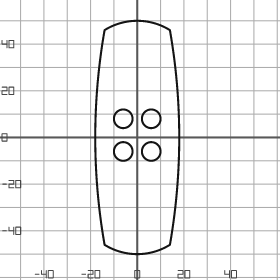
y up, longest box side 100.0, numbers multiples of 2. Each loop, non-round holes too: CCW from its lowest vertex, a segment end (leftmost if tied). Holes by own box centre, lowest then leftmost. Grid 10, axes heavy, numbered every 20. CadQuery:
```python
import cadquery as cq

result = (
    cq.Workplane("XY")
    .moveTo(-14.0, -46.0)
    .threePointArc((0.0, -50.0), (14.0, -46.0))
    .threePointArc((18.0, 0.0), (14.0, 46.0))
    .threePointArc((0.0, 50.0), (-14.0, 46.0))
    .threePointArc((-18.0, 0.0), (-14.0, -46.0))
    .close()
    .moveTo(-6.0, -6.0)
    .circle(4.0)
    .moveTo(6.0, -6.0)
    .circle(4.0)
    .moveTo(-6.0, 8.0)
    .circle(4.0)
    .moveTo(6.0, 8.0)
    .circle(4.0)
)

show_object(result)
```